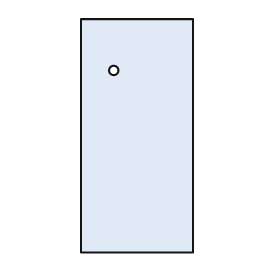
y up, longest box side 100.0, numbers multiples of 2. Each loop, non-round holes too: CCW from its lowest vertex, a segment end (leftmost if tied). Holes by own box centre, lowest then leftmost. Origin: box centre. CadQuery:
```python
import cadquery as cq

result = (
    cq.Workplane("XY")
    .moveTo(-24.0, -50.0)
    .lineTo(24.0, -50.0)
    .lineTo(24.0, 50.0)
    .lineTo(-24.0, 50.0)
    .close()
    .moveTo(-10.0, 28.0)
    .circle(2.0)
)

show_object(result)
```